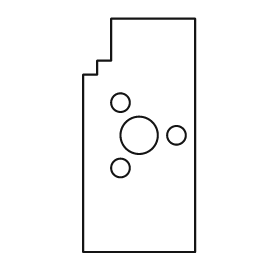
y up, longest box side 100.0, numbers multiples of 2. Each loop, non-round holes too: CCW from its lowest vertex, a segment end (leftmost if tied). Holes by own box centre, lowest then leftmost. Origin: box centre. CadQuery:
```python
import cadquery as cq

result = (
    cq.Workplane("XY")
    .moveTo(-24.0, -50.0)
    .lineTo(24.0, -50.0)
    .lineTo(24.0, 50.0)
    .lineTo(-12.0, 50.0)
    .lineTo(-12.0, 32.0)
    .lineTo(-18.0, 32.0)
    .lineTo(-18.0, 26.0)
    .lineTo(-24.0, 26.0)
    .close()
    .moveTo(-8.0, -14.0)
    .circle(4.0)
    .moveTo(0.0, 0.0)
    .circle(8.0)
    .moveTo(16.0, 0.0)
    .circle(4.0)
    .moveTo(-8.0, 14.0)
    .circle(4.0)
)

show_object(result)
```